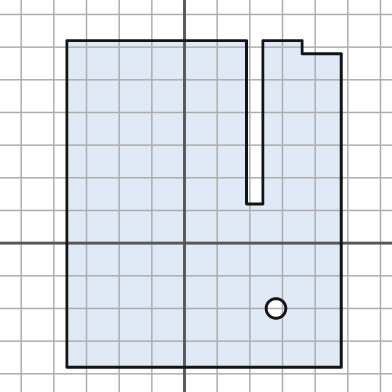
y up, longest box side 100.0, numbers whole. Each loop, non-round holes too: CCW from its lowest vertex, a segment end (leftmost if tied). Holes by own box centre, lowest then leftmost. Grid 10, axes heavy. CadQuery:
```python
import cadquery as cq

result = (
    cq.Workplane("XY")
    .moveTo(-36.0, -38.0)
    .lineTo(48.0, -38.0)
    .lineTo(48.0, 58.0)
    .lineTo(36.0, 58.0)
    .lineTo(36.0, 62.0)
    .lineTo(24.0, 62.0)
    .lineTo(24.0, 12.0)
    .lineTo(19.0, 12.0)
    .lineTo(19.0, 62.0)
    .lineTo(-36.0, 62.0)
    .close()
    .moveTo(28.0, -20.0)
    .circle(3.0)
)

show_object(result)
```